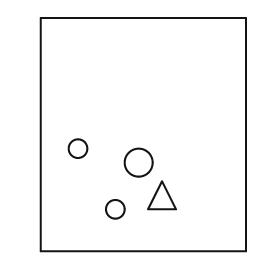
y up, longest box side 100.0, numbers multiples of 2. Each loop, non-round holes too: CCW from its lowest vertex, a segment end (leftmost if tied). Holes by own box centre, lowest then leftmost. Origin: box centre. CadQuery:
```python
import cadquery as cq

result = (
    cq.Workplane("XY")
    .moveTo(-44.0, -50.0)
    .lineTo(44.0, -50.0)
    .lineTo(44.0, 50.0)
    .lineTo(-44.0, 50.0)
    .close()
    .moveTo(-12.0, -32.0)
    .circle(4.0)
    .moveTo(2.0, -32.0)
    .lineTo(14.0, -32.0)
    .lineTo(8.0, -20.0)
    .close()
    .moveTo(-2.0, -12.0)
    .circle(6.0)
    .moveTo(-28.0, -6.0)
    .circle(4.0)
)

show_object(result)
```